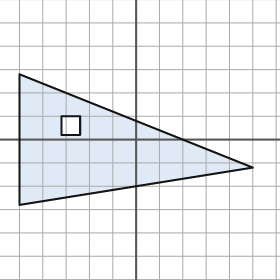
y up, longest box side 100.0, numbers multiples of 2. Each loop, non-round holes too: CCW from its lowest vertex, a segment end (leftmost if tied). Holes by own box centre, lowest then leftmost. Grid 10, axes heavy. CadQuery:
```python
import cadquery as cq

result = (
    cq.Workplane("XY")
    .moveTo(-50.0, -28.0)
    .lineTo(50.0, -12.0)
    .lineTo(-50.0, 28.0)
    .close()
    .moveTo(-32.0, 2.0)
    .lineTo(-24.0, 2.0)
    .lineTo(-24.0, 10.0)
    .lineTo(-32.0, 10.0)
    .close()
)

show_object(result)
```